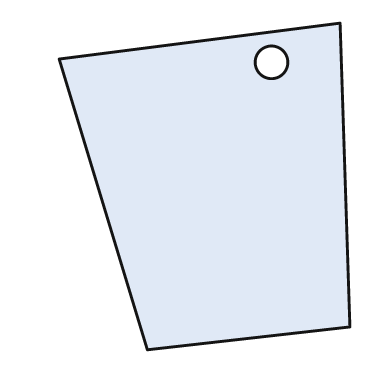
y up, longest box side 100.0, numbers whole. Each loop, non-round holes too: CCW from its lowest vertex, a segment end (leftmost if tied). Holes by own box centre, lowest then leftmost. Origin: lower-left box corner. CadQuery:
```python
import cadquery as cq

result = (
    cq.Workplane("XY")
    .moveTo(27.0, 0.0)
    .lineTo(89.0, 7.0)
    .lineTo(86.0, 100.0)
    .lineTo(0.0, 89.0)
    .close()
    .moveTo(65.0, 88.0)
    .circle(5.0)
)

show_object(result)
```